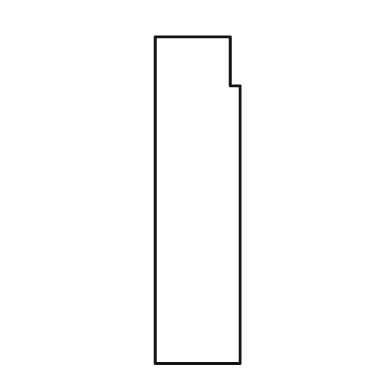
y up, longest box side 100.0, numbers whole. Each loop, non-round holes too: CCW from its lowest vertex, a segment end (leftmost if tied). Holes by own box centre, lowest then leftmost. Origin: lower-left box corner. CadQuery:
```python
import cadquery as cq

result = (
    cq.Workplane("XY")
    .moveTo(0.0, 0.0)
    .lineTo(26.0, 0.0)
    .lineTo(26.0, 85.0)
    .lineTo(23.0, 85.0)
    .lineTo(23.0, 100.0)
    .lineTo(0.0, 100.0)
    .close()
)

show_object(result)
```